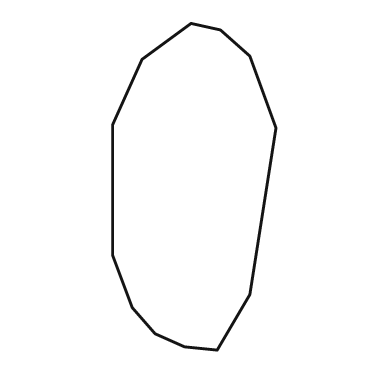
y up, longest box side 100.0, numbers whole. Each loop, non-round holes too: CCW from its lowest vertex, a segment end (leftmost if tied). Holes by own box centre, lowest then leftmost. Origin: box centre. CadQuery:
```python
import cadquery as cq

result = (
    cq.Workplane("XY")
    .moveTo(7.0, -50.0)
    .lineTo(17.0, -33.0)
    .lineTo(25.0, 18.0)
    .lineTo(17.0, 40.0)
    .lineTo(8.0, 48.0)
    .lineTo(-1.0, 50.0)
    .lineTo(-16.0, 39.0)
    .lineTo(-25.0, 19.0)
    .lineTo(-25.0, -21.0)
    .lineTo(-19.0, -37.0)
    .lineTo(-12.0, -45.0)
    .lineTo(-3.0, -49.0)
    .close()
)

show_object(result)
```